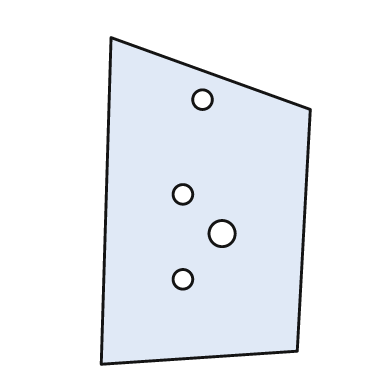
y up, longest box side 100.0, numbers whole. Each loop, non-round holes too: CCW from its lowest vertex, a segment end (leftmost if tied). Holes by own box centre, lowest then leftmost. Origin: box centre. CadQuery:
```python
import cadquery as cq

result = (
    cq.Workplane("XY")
    .moveTo(-32.0, -50.0)
    .lineTo(28.0, -46.0)
    .lineTo(32.0, 28.0)
    .lineTo(-29.0, 50.0)
    .close()
    .moveTo(-7.0, -24.0)
    .circle(3.0)
    .moveTo(5.0, -10.0)
    .circle(4.0)
    .moveTo(-7.0, 2.0)
    .circle(3.0)
    .moveTo(-1.0, 31.0)
    .circle(3.0)
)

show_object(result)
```